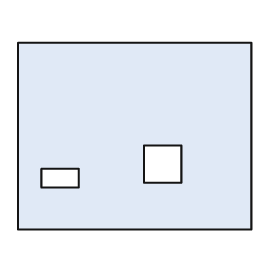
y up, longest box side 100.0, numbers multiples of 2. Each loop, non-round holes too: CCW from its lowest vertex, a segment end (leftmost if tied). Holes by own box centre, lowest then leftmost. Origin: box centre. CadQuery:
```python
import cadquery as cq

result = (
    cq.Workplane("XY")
    .moveTo(-50.0, -40.0)
    .lineTo(50.0, -40.0)
    .lineTo(50.0, 40.0)
    .lineTo(-50.0, 40.0)
    .close()
    .moveTo(-40.0, -22.0)
    .lineTo(-24.0, -22.0)
    .lineTo(-24.0, -14.0)
    .lineTo(-40.0, -14.0)
    .close()
    .moveTo(4.0, -20.0)
    .lineTo(20.0, -20.0)
    .lineTo(20.0, -4.0)
    .lineTo(4.0, -4.0)
    .close()
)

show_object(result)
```